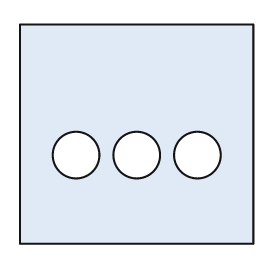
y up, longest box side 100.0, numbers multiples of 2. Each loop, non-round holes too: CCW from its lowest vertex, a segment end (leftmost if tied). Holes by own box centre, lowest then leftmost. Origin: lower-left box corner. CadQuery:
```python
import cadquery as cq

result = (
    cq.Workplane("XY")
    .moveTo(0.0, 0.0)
    .lineTo(100.0, 0.0)
    .lineTo(100.0, 94.0)
    .lineTo(0.0, 94.0)
    .close()
    .moveTo(24.0, 38.0)
    .circle(10.0)
    .moveTo(50.0, 38.0)
    .circle(10.0)
    .moveTo(76.0, 38.0)
    .circle(10.0)
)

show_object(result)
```